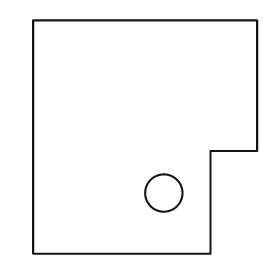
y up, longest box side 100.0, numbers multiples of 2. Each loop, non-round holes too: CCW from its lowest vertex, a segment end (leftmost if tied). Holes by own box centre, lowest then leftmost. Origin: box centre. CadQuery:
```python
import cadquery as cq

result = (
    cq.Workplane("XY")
    .moveTo(-48.0, -50.0)
    .lineTo(28.0, -50.0)
    .lineTo(28.0, -6.0)
    .lineTo(48.0, -6.0)
    .lineTo(48.0, 50.0)
    .lineTo(-48.0, 50.0)
    .close()
    .moveTo(8.0, -24.0)
    .circle(8.0)
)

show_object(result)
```